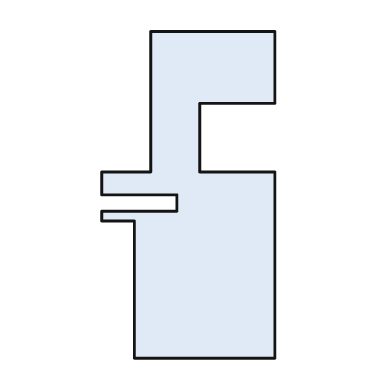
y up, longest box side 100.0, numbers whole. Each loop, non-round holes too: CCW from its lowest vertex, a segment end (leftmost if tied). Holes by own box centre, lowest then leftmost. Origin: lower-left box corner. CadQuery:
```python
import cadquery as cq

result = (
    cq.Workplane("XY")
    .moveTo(10.0, 0.0)
    .lineTo(53.0, 0.0)
    .lineTo(53.0, 57.0)
    .lineTo(30.0, 57.0)
    .lineTo(30.0, 78.0)
    .lineTo(53.0, 78.0)
    .lineTo(53.0, 100.0)
    .lineTo(15.0, 100.0)
    .lineTo(15.0, 57.0)
    .lineTo(0.0, 57.0)
    .lineTo(0.0, 50.0)
    .lineTo(23.0, 50.0)
    .lineTo(23.0, 45.0)
    .lineTo(0.0, 45.0)
    .lineTo(0.0, 42.0)
    .lineTo(10.0, 42.0)
    .close()
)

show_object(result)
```